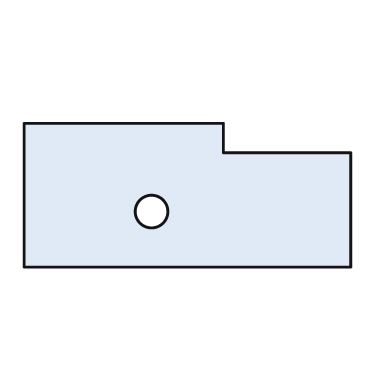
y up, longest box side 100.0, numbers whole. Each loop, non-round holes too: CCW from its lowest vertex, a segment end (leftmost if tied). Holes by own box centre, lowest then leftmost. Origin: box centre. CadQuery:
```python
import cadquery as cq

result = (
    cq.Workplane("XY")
    .moveTo(-50.0, -22.0)
    .lineTo(50.0, -22.0)
    .lineTo(50.0, 13.0)
    .lineTo(11.0, 13.0)
    .lineTo(11.0, 22.0)
    .lineTo(-50.0, 22.0)
    .close()
    .moveTo(-11.0, -5.0)
    .circle(5.0)
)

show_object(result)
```